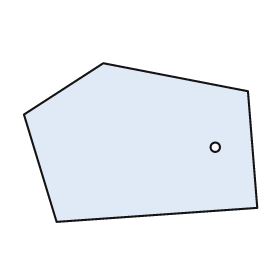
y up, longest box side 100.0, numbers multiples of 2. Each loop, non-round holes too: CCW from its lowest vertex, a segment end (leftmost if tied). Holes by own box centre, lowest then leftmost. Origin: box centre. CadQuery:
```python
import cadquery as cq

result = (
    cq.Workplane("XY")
    .moveTo(-36.0, -34.0)
    .lineTo(50.0, -28.0)
    .lineTo(46.0, 22.0)
    .lineTo(-16.0, 34.0)
    .lineTo(-50.0, 12.0)
    .close()
    .moveTo(32.0, -2.0)
    .circle(2.0)
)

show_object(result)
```